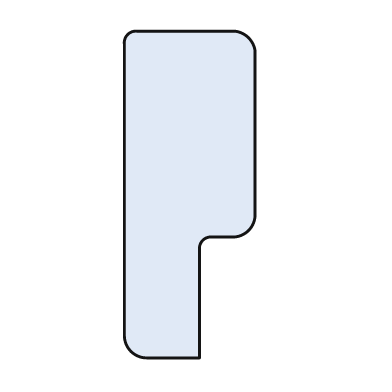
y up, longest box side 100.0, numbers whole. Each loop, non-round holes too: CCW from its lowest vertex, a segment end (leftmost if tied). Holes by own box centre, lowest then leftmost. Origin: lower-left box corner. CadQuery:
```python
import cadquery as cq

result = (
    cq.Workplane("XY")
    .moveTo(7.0, 0.0)
    .lineTo(23.0, 0.0)
    .lineTo(23.0, 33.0)
    .threePointArc((24.0, 36.0), (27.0, 37.0))
    .lineTo(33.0, 37.0)
    .threePointArc((38.0, 39.0), (40.0, 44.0))
    .lineTo(40.0, 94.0)
    .threePointArc((38.0, 98.0), (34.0, 100.0))
    .lineTo(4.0, 100.0)
    .threePointArc((1.0, 99.0), (0.0, 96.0))
    .lineTo(0.0, 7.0)
    .threePointArc((2.0, 2.0), (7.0, 0.0))
    .close()
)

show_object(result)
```